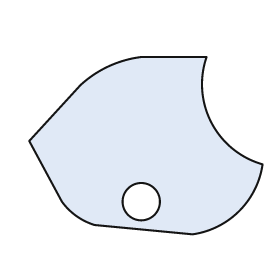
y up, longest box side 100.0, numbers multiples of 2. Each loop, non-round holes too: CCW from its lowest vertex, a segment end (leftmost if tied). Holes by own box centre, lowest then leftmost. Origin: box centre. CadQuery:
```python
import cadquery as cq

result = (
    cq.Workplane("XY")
    .moveTo(20.0, -38.0)
    .threePointArc((40.0, -28.0), (50.0, -8.0))
    .threePointArc((28.0, 10.0), (26.0, 38.0))
    .lineTo(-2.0, 38.0)
    .threePointArc((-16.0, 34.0), (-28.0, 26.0))
    .lineTo(-50.0, 2.0)
    .lineTo(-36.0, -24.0)
    .threePointArc((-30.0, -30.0), (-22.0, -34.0))
    .close()
    .moveTo(-2.0, -24.0)
    .circle(8.0)
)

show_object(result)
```